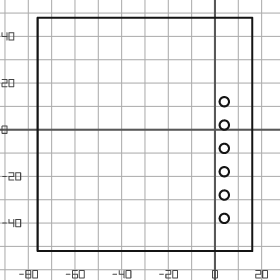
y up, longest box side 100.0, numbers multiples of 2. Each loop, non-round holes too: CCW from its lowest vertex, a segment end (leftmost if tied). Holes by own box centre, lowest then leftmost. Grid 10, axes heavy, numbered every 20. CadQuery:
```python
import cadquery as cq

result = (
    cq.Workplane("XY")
    .moveTo(-76.0, -52.0)
    .lineTo(16.0, -52.0)
    .lineTo(16.0, 48.0)
    .lineTo(-76.0, 48.0)
    .close()
    .moveTo(4.0, -38.0)
    .circle(2.0)
    .moveTo(4.0, -28.0)
    .circle(2.0)
    .moveTo(4.0, -18.0)
    .circle(2.0)
    .moveTo(4.0, -8.0)
    .circle(2.0)
    .moveTo(4.0, 2.0)
    .circle(2.0)
    .moveTo(4.0, 12.0)
    .circle(2.0)
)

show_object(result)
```